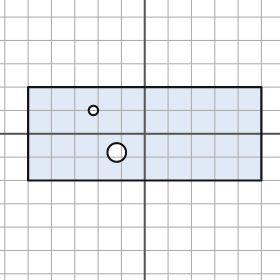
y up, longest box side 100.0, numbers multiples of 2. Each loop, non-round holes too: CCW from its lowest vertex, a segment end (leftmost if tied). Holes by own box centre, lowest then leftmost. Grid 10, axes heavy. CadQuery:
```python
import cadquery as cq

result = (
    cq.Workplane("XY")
    .moveTo(-50.0, -20.0)
    .lineTo(50.0, -20.0)
    .lineTo(50.0, 20.0)
    .lineTo(-50.0, 20.0)
    .close()
    .moveTo(-12.0, -8.0)
    .circle(4.0)
    .moveTo(-22.0, 10.0)
    .circle(2.0)
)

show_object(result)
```